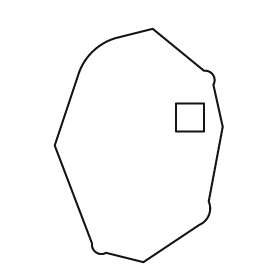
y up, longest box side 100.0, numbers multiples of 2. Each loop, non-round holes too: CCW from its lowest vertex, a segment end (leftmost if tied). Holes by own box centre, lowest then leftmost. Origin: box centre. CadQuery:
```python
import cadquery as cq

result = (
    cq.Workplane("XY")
    .moveTo(2.0, -50.0)
    .lineTo(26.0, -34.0)
    .threePointArc((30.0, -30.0), (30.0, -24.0))
    .lineTo(36.0, 8.0)
    .lineTo(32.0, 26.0)
    .threePointArc((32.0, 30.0), (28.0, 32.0))
    .lineTo(6.0, 50.0)
    .lineTo(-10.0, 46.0)
    .threePointArc((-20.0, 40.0), (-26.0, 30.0))
    .lineTo(-36.0, 0.0)
    .lineTo(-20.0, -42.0)
    .threePointArc((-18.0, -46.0), (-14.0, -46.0))
    .close()
    .moveTo(16.0, 6.0)
    .lineTo(28.0, 6.0)
    .lineTo(28.0, 18.0)
    .lineTo(16.0, 18.0)
    .close()
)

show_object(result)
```